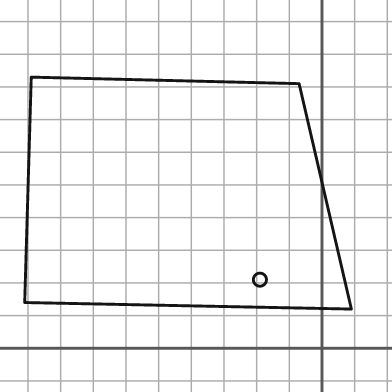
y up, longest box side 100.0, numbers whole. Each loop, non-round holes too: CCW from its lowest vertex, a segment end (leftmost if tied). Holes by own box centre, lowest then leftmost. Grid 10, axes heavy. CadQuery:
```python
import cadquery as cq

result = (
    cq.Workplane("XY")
    .moveTo(9.0, 12.0)
    .lineTo(-7.0, 81.0)
    .lineTo(-89.0, 83.0)
    .lineTo(-91.0, 14.0)
    .close()
    .moveTo(-19.0, 21.0)
    .circle(2.0)
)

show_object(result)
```